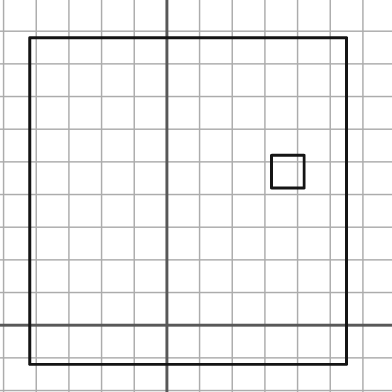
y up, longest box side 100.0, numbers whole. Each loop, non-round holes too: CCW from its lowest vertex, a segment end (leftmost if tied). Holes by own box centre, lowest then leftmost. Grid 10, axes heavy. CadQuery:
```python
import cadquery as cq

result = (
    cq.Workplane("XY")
    .moveTo(-42.0, -12.0)
    .lineTo(55.0, -12.0)
    .lineTo(55.0, 88.0)
    .lineTo(-42.0, 88.0)
    .close()
    .moveTo(32.0, 42.0)
    .lineTo(42.0, 42.0)
    .lineTo(42.0, 52.0)
    .lineTo(32.0, 52.0)
    .close()
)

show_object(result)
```